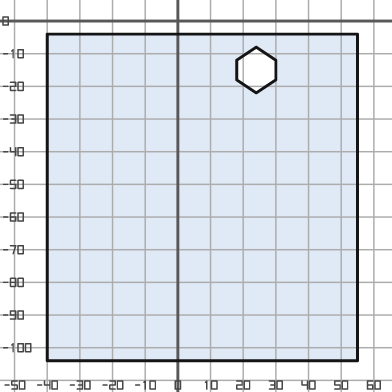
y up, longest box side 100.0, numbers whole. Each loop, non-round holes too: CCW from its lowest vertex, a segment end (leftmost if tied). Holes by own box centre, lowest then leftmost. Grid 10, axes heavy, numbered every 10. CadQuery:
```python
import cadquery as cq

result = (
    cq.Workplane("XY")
    .moveTo(-40.0, -104.0)
    .lineTo(55.0, -104.0)
    .lineTo(55.0, -4.0)
    .lineTo(-40.0, -4.0)
    .close()
    .moveTo(24.0, -22.0)
    .lineTo(30.0, -18.0)
    .lineTo(30.0, -12.0)
    .lineTo(24.0, -8.0)
    .lineTo(18.0, -12.0)
    .lineTo(18.0, -18.0)
    .close()
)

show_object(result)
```